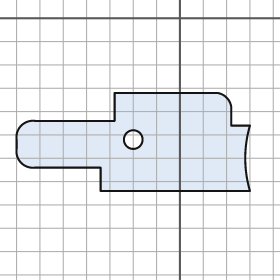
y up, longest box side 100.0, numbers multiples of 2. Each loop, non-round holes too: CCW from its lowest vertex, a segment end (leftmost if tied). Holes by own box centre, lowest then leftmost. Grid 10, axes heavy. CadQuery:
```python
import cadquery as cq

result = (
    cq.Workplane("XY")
    .moveTo(-34.0, -74.0)
    .lineTo(30.0, -74.0)
    .threePointArc((28.0, -60.0), (30.0, -46.0))
    .lineTo(22.0, -46.0)
    .lineTo(22.0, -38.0)
    .threePointArc((20.0, -34.0), (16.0, -32.0))
    .lineTo(-28.0, -32.0)
    .lineTo(-28.0, -44.0)
    .lineTo(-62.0, -44.0)
    .threePointArc((-68.0, -46.0), (-70.0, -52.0))
    .lineTo(-70.0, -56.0)
    .threePointArc((-68.0, -62.0), (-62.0, -64.0))
    .lineTo(-34.0, -64.0)
    .close()
    .moveTo(-20.0, -52.0)
    .circle(4.0)
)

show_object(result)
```